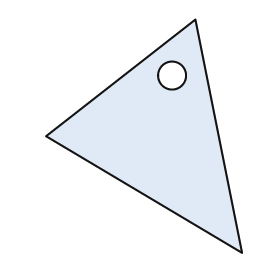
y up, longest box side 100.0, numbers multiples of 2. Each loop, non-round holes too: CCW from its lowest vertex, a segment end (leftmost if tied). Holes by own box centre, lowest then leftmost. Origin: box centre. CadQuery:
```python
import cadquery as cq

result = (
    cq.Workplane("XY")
    .moveTo(42.0, -50.0)
    .lineTo(22.0, 50.0)
    .lineTo(-42.0, 0.0)
    .close()
    .moveTo(12.0, 26.0)
    .circle(6.0)
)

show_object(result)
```